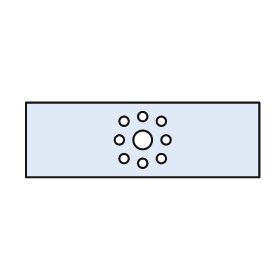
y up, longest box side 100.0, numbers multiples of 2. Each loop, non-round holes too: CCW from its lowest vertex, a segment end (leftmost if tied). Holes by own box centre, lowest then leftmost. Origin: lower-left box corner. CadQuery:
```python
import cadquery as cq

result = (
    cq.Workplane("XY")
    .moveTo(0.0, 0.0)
    .lineTo(100.0, 0.0)
    .lineTo(100.0, 32.0)
    .lineTo(0.0, 32.0)
    .close()
    .moveTo(50.0, 6.0)
    .circle(2.0)
    .moveTo(42.0, 8.0)
    .circle(2.0)
    .moveTo(58.0, 8.0)
    .circle(2.0)
    .moveTo(40.0, 16.0)
    .circle(2.0)
    .moveTo(50.0, 16.0)
    .circle(4.0)
    .moveTo(60.0, 16.0)
    .circle(2.0)
    .moveTo(42.0, 24.0)
    .circle(2.0)
    .moveTo(58.0, 24.0)
    .circle(2.0)
    .moveTo(50.0, 26.0)
    .circle(2.0)
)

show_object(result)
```